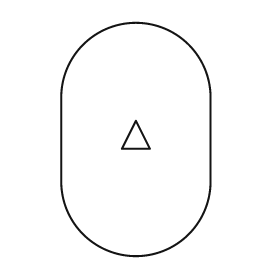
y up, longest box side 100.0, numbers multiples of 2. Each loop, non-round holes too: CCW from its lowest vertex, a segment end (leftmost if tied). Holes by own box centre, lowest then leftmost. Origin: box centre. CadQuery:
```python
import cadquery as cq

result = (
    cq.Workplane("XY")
    .moveTo(-32.0, -18.0)
    .threePointArc((0.0, -50.0), (32.0, -18.0))
    .lineTo(32.0, 18.0)
    .threePointArc((0.0, 50.0), (-32.0, 18.0))
    .close()
    .moveTo(-6.0, -4.0)
    .lineTo(6.0, -4.0)
    .lineTo(0.0, 8.0)
    .close()
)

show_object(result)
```